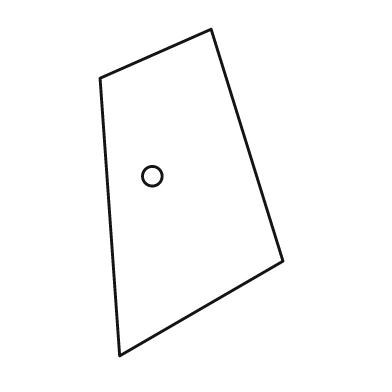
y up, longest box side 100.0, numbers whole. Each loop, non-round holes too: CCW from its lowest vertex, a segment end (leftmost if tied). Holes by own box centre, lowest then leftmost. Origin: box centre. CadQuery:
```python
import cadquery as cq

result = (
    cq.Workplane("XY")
    .moveTo(-22.0, -50.0)
    .lineTo(28.0, -21.0)
    .lineTo(6.0, 50.0)
    .lineTo(-28.0, 35.0)
    .close()
    .moveTo(-12.0, 5.0)
    .circle(3.0)
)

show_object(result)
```